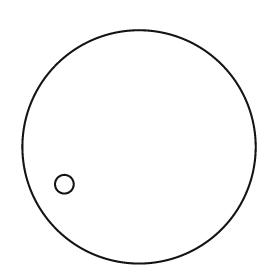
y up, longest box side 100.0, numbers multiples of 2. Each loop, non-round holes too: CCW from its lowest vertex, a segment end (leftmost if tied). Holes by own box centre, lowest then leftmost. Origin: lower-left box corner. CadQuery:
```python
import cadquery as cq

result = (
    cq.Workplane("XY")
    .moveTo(50.0, 50.0)
    .circle(50.0)
    .moveTo(18.0, 34.0)
    .circle(4.0)
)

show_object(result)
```